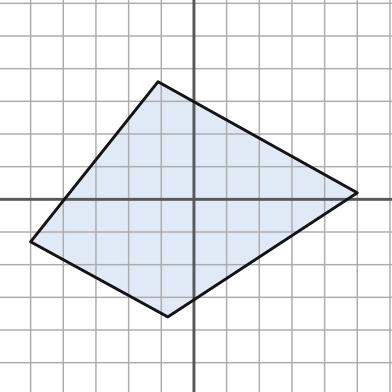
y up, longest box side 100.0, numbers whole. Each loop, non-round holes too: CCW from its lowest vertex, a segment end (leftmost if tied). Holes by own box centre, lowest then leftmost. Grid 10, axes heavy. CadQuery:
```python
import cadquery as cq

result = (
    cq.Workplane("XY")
    .moveTo(-8.0, -36.0)
    .lineTo(50.0, 2.0)
    .lineTo(-11.0, 36.0)
    .lineTo(-50.0, -13.0)
    .close()
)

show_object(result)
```